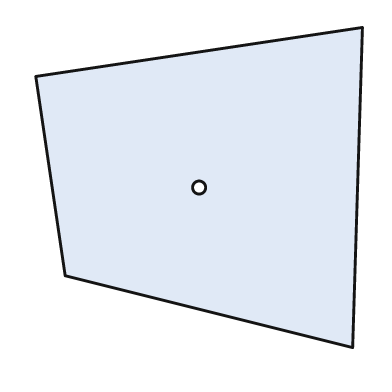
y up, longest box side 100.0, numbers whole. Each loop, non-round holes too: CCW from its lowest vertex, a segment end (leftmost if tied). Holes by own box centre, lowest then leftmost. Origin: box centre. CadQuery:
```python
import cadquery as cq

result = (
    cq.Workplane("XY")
    .moveTo(47.0, -49.0)
    .lineTo(50.0, 49.0)
    .lineTo(-50.0, 34.0)
    .lineTo(-41.0, -27.0)
    .close()
    .moveTo(0.0, 0.0)
    .circle(2.0)
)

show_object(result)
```